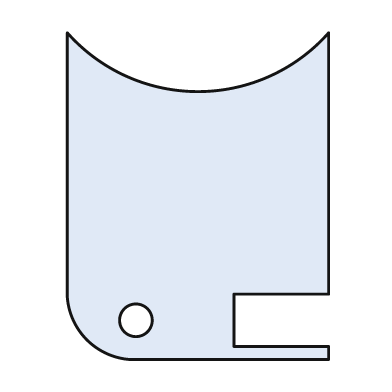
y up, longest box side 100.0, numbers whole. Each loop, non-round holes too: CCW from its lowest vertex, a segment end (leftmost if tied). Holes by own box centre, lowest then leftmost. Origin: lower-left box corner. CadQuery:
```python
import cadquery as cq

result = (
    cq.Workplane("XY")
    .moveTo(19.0, 0.0)
    .lineTo(80.0, 0.0)
    .lineTo(80.0, 4.0)
    .lineTo(51.0, 4.0)
    .lineTo(51.0, 20.0)
    .lineTo(80.0, 20.0)
    .lineTo(80.0, 100.0)
    .threePointArc((40.0, 82.0), (0.0, 100.0))
    .lineTo(0.0, 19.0)
    .threePointArc((6.0, 6.0), (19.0, 0.0))
    .close()
    .moveTo(21.0, 12.0)
    .circle(5.0)
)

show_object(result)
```